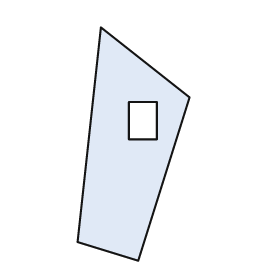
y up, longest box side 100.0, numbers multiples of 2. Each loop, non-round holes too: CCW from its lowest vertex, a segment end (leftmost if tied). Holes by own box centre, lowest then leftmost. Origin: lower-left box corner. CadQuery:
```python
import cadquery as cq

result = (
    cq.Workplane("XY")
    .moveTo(26.0, 0.0)
    .lineTo(48.0, 70.0)
    .lineTo(10.0, 100.0)
    .lineTo(0.0, 8.0)
    .close()
    .moveTo(22.0, 52.0)
    .lineTo(34.0, 52.0)
    .lineTo(34.0, 68.0)
    .lineTo(22.0, 68.0)
    .close()
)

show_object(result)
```